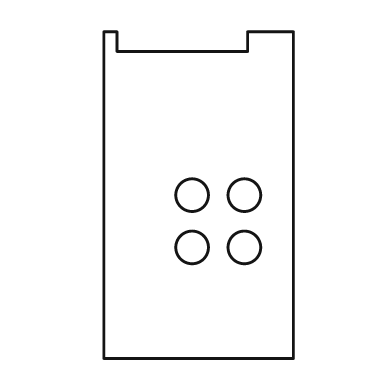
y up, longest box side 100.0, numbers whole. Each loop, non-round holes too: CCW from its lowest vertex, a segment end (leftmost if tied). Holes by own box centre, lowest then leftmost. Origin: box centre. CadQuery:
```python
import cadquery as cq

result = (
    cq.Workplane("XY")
    .moveTo(-29.0, -50.0)
    .lineTo(29.0, -50.0)
    .lineTo(29.0, 50.0)
    .lineTo(15.0, 50.0)
    .lineTo(15.0, 44.0)
    .lineTo(-25.0, 44.0)
    .lineTo(-25.0, 50.0)
    .lineTo(-29.0, 50.0)
    .close()
    .moveTo(-2.0, -16.0)
    .circle(5.0)
    .moveTo(14.0, -16.0)
    .circle(5.0)
    .moveTo(-2.0, 0.0)
    .circle(5.0)
    .moveTo(14.0, 0.0)
    .circle(5.0)
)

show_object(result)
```